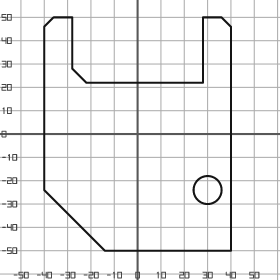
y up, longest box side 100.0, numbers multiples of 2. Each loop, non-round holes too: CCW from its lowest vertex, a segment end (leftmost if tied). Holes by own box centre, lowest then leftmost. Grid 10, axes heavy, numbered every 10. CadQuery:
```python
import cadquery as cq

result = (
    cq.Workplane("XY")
    .moveTo(-14.0, -50.0)
    .lineTo(40.0, -50.0)
    .lineTo(40.0, 46.0)
    .lineTo(36.0, 50.0)
    .lineTo(28.0, 50.0)
    .lineTo(28.0, 22.0)
    .lineTo(-22.0, 22.0)
    .lineTo(-28.0, 28.0)
    .lineTo(-28.0, 50.0)
    .lineTo(-36.0, 50.0)
    .lineTo(-40.0, 46.0)
    .lineTo(-40.0, -24.0)
    .close()
    .moveTo(30.0, -24.0)
    .circle(6.0)
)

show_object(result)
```